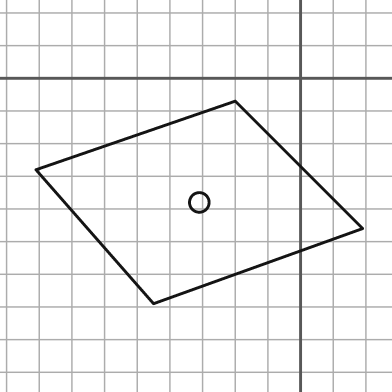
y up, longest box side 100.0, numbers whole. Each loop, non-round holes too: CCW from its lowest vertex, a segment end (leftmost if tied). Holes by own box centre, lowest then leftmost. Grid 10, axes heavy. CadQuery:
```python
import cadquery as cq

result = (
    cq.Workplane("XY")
    .moveTo(-45.0, -69.0)
    .lineTo(19.0, -46.0)
    .lineTo(-20.0, -7.0)
    .lineTo(-81.0, -28.0)
    .close()
    .moveTo(-31.0, -38.0)
    .circle(3.0)
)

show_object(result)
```